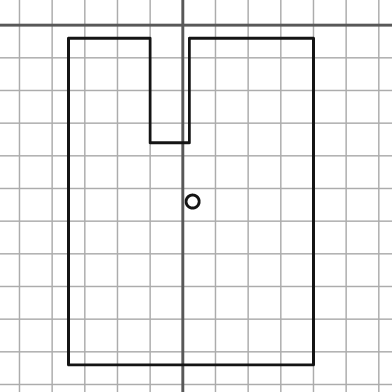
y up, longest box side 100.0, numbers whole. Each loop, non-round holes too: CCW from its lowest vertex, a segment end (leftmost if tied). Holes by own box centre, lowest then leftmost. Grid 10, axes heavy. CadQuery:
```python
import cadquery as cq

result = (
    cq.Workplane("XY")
    .moveTo(-35.0, -104.0)
    .lineTo(40.0, -104.0)
    .lineTo(40.0, -4.0)
    .lineTo(2.0, -4.0)
    .lineTo(2.0, -36.0)
    .lineTo(-10.0, -36.0)
    .lineTo(-10.0, -4.0)
    .lineTo(-35.0, -4.0)
    .close()
    .moveTo(3.0, -54.0)
    .circle(2.0)
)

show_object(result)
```